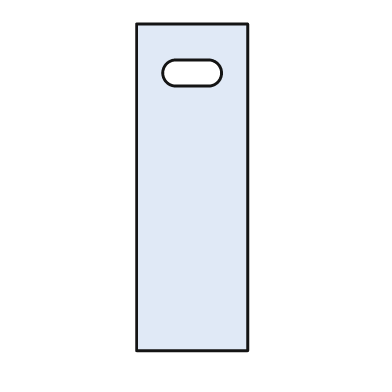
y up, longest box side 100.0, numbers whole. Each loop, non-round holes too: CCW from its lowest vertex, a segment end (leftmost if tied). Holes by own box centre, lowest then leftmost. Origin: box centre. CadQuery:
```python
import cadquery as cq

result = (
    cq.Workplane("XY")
    .moveTo(-17.0, -50.0)
    .lineTo(17.0, -50.0)
    .lineTo(17.0, 50.0)
    .lineTo(-17.0, 50.0)
    .close()
    .moveTo(-5.0, 31.0)
    .lineTo(5.0, 31.0)
    .threePointArc((9.0, 35.0), (5.0, 39.0))
    .lineTo(-5.0, 39.0)
    .threePointArc((-9.0, 35.0), (-5.0, 31.0))
    .close()
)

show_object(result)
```